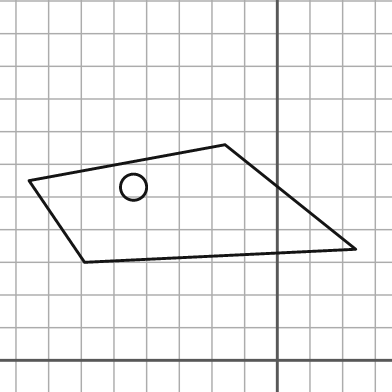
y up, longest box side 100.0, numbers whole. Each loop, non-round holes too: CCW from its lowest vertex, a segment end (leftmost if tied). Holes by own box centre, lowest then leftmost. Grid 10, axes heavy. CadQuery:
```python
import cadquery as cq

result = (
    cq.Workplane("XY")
    .moveTo(-59.0, 30.0)
    .lineTo(24.0, 34.0)
    .lineTo(-16.0, 66.0)
    .lineTo(-76.0, 55.0)
    .close()
    .moveTo(-44.0, 53.0)
    .circle(4.0)
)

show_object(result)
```